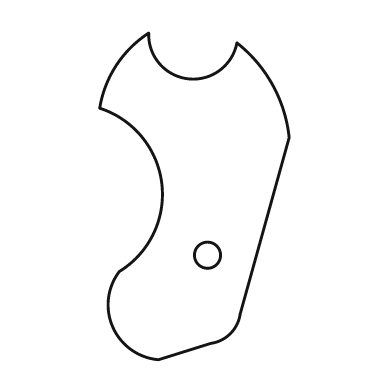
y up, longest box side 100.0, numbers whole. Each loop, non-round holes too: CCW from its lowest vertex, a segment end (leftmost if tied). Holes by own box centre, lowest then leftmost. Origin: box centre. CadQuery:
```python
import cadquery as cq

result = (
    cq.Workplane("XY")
    .moveTo(-11.0, -50.0)
    .lineTo(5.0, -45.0)
    .threePointArc((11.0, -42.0), (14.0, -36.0))
    .lineTo(29.0, 18.0)
    .threePointArc((24.0, 34.0), (13.0, 47.0))
    .threePointArc((-2.0, 36.0), (-14.0, 50.0))
    .threePointArc((-24.0, 40.0), (-29.0, 27.0))
    .threePointArc((-10.0, 4.0), (-23.0, -23.0))
    .threePointArc((-25.0, -40.0), (-11.0, -50.0))
    .close()
    .moveTo(4.0, -18.0)
    .circle(4.0)
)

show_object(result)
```